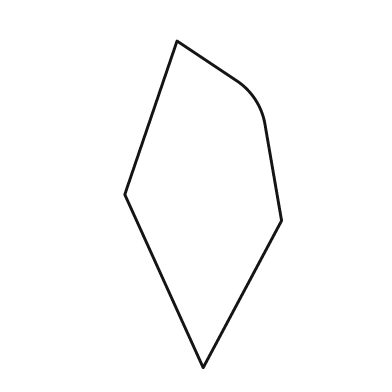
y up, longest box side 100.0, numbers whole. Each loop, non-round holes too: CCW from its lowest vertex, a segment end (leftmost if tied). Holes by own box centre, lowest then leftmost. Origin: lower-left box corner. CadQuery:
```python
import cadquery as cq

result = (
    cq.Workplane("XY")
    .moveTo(24.0, 0.0)
    .lineTo(48.0, 45.0)
    .lineTo(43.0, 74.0)
    .threePointArc((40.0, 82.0), (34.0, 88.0))
    .lineTo(16.0, 100.0)
    .lineTo(0.0, 53.0)
    .close()
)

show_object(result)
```